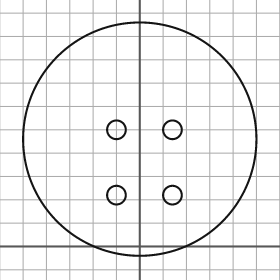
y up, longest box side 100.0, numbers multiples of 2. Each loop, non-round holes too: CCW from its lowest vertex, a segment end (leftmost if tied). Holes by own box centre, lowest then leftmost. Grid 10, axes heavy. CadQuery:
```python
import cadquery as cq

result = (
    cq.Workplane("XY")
    .moveTo(0.0, 46.0)
    .circle(50.0)
    .moveTo(-10.0, 22.0)
    .circle(4.0)
    .moveTo(14.0, 22.0)
    .circle(4.0)
    .moveTo(-10.0, 50.0)
    .circle(4.0)
    .moveTo(14.0, 50.0)
    .circle(4.0)
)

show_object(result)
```